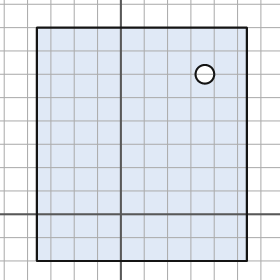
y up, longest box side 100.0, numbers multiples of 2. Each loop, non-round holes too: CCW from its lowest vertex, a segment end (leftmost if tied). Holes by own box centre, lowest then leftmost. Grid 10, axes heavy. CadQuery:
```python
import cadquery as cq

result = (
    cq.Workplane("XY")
    .moveTo(-36.0, -20.0)
    .lineTo(54.0, -20.0)
    .lineTo(54.0, 80.0)
    .lineTo(-36.0, 80.0)
    .close()
    .moveTo(36.0, 60.0)
    .circle(4.0)
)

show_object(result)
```